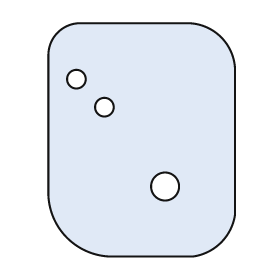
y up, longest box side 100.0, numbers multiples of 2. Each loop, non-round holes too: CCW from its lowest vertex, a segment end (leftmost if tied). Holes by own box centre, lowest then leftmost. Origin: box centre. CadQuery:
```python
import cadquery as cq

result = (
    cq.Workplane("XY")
    .moveTo(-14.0, -50.0)
    .lineTo(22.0, -50.0)
    .threePointArc((34.0, -44.0), (40.0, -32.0))
    .lineTo(40.0, 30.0)
    .threePointArc((34.0, 44.0), (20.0, 50.0))
    .lineTo(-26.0, 50.0)
    .threePointArc((-36.0, 46.0), (-40.0, 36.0))
    .lineTo(-40.0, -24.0)
    .threePointArc((-32.0, -42.0), (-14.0, -50.0))
    .close()
    .moveTo(10.0, -20.0)
    .circle(6.0)
    .moveTo(-16.0, 14.0)
    .circle(4.0)
    .moveTo(-28.0, 26.0)
    .circle(4.0)
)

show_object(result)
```